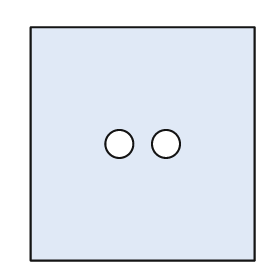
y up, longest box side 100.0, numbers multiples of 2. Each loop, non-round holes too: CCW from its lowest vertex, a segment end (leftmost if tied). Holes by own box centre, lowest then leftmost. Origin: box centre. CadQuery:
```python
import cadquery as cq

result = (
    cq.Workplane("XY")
    .moveTo(-48.0, -50.0)
    .lineTo(48.0, -50.0)
    .lineTo(48.0, 50.0)
    .lineTo(-48.0, 50.0)
    .close()
    .moveTo(-10.0, 0.0)
    .circle(6.0)
    .moveTo(10.0, 0.0)
    .circle(6.0)
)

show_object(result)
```